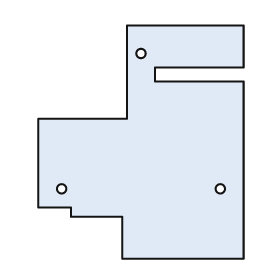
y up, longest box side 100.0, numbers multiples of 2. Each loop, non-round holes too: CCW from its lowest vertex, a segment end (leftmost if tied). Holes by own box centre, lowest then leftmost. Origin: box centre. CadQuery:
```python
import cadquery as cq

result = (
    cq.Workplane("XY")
    .moveTo(-8.0, -50.0)
    .lineTo(44.0, -50.0)
    .lineTo(44.0, 26.0)
    .lineTo(6.0, 26.0)
    .lineTo(6.0, 32.0)
    .lineTo(44.0, 32.0)
    .lineTo(44.0, 50.0)
    .lineTo(-6.0, 50.0)
    .lineTo(-6.0, 10.0)
    .lineTo(-44.0, 10.0)
    .lineTo(-44.0, -28.0)
    .lineTo(-30.0, -28.0)
    .lineTo(-30.0, -32.0)
    .lineTo(-8.0, -32.0)
    .close()
    .moveTo(-34.0, -20.0)
    .circle(2.0)
    .moveTo(34.0, -20.0)
    .circle(2.0)
    .moveTo(0.0, 38.0)
    .circle(2.0)
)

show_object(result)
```